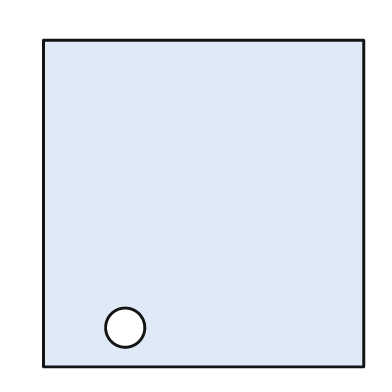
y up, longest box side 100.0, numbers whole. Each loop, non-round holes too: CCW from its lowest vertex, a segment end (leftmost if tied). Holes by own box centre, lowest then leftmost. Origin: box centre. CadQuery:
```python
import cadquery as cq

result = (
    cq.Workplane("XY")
    .moveTo(-49.0, -50.0)
    .lineTo(49.0, -50.0)
    .lineTo(49.0, 50.0)
    .lineTo(-49.0, 50.0)
    .close()
    .moveTo(-24.0, -38.0)
    .circle(6.0)
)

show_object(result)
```